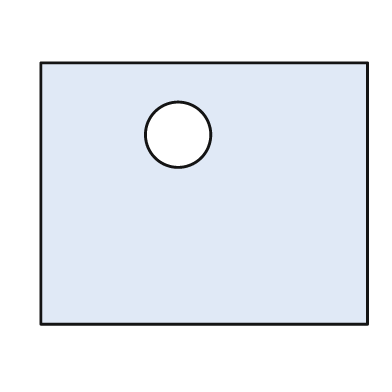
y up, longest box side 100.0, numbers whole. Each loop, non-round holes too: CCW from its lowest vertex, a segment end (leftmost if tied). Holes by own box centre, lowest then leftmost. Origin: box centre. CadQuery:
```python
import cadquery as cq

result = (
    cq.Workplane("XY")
    .moveTo(-50.0, -40.0)
    .lineTo(50.0, -40.0)
    .lineTo(50.0, 40.0)
    .lineTo(-50.0, 40.0)
    .close()
    .moveTo(-8.0, 18.0)
    .circle(10.0)
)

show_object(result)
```